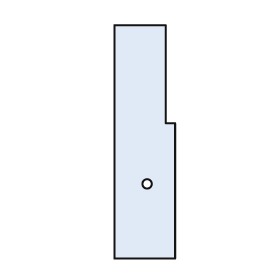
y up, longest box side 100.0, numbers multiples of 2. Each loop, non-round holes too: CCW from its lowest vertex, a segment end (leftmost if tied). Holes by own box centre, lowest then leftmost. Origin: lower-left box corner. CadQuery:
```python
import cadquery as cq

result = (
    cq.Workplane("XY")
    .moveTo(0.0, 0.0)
    .lineTo(26.0, 0.0)
    .lineTo(26.0, 58.0)
    .lineTo(22.0, 58.0)
    .lineTo(22.0, 100.0)
    .lineTo(0.0, 100.0)
    .close()
    .moveTo(14.0, 32.0)
    .circle(2.0)
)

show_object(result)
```